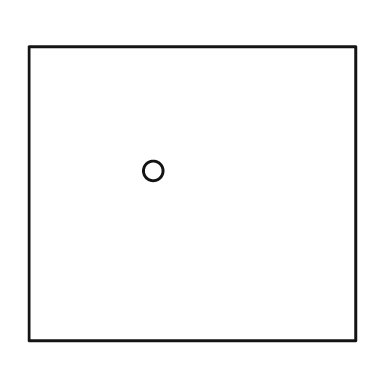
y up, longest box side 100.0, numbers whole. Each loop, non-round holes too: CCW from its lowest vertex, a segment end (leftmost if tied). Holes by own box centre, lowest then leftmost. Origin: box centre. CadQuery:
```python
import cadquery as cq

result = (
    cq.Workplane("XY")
    .moveTo(-50.0, -45.0)
    .lineTo(50.0, -45.0)
    .lineTo(50.0, 45.0)
    .lineTo(-50.0, 45.0)
    .close()
    .moveTo(-12.0, 7.0)
    .circle(3.0)
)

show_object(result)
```